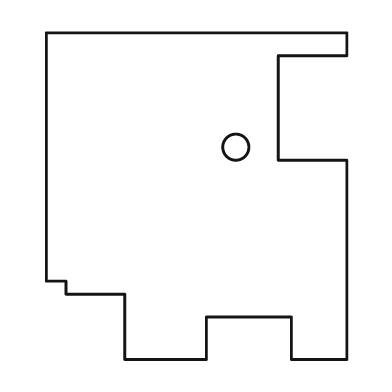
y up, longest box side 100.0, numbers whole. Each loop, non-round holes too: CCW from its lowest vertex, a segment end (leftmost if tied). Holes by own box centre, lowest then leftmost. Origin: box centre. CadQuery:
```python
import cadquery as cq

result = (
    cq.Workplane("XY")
    .moveTo(-22.0, -50.0)
    .lineTo(3.0, -50.0)
    .lineTo(3.0, -37.0)
    .lineTo(29.0, -37.0)
    .lineTo(29.0, -50.0)
    .lineTo(46.0, -50.0)
    .lineTo(46.0, 11.0)
    .lineTo(25.0, 11.0)
    .lineTo(25.0, 43.0)
    .lineTo(46.0, 43.0)
    .lineTo(46.0, 50.0)
    .lineTo(-46.0, 50.0)
    .lineTo(-46.0, -26.0)
    .lineTo(-40.0, -26.0)
    .lineTo(-40.0, -30.0)
    .lineTo(-22.0, -30.0)
    .close()
    .moveTo(12.0, 15.0)
    .circle(4.0)
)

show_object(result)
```